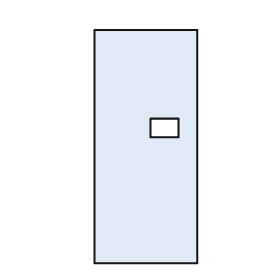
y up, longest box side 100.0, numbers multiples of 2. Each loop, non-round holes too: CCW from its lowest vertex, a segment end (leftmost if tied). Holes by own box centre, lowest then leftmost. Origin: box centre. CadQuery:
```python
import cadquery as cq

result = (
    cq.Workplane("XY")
    .moveTo(-22.0, -50.0)
    .lineTo(22.0, -50.0)
    .lineTo(22.0, 50.0)
    .lineTo(-22.0, 50.0)
    .close()
    .moveTo(2.0, 4.0)
    .lineTo(14.0, 4.0)
    .lineTo(14.0, 12.0)
    .lineTo(2.0, 12.0)
    .close()
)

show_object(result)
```